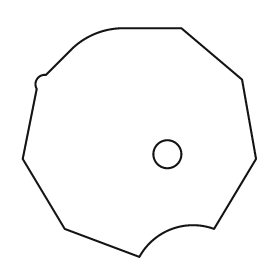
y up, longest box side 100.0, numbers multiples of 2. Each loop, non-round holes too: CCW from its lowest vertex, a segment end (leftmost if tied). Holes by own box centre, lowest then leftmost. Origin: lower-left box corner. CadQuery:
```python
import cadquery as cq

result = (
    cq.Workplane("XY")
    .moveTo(50.0, 0.0)
    .threePointArc((64.0, 12.0), (82.0, 12.0))
    .lineTo(100.0, 42.0)
    .lineTo(94.0, 76.0)
    .lineTo(68.0, 98.0)
    .lineTo(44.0, 98.0)
    .threePointArc((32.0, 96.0), (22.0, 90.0))
    .lineTo(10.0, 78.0)
    .threePointArc((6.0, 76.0), (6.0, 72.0))
    .lineTo(0.0, 42.0)
    .lineTo(18.0, 12.0)
    .close()
    .moveTo(62.0, 44.0)
    .circle(6.0)
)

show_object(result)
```